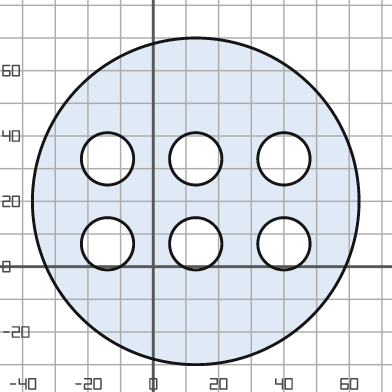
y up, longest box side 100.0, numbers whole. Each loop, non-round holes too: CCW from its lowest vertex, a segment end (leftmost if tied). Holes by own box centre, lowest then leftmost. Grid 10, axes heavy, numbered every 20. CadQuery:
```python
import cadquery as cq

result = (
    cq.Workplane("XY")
    .moveTo(13.0, 20.0)
    .circle(50.0)
    .moveTo(-14.0, 7.0)
    .circle(8.0)
    .moveTo(13.0, 7.0)
    .circle(8.0)
    .moveTo(40.0, 7.0)
    .circle(8.0)
    .moveTo(-14.0, 33.0)
    .circle(8.0)
    .moveTo(13.0, 33.0)
    .circle(8.0)
    .moveTo(40.0, 33.0)
    .circle(8.0)
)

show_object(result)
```